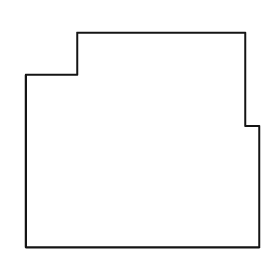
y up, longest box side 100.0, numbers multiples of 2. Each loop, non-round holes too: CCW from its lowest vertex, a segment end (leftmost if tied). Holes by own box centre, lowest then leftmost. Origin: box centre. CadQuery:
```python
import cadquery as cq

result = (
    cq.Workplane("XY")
    .moveTo(-50.0, -46.0)
    .lineTo(50.0, -46.0)
    .lineTo(50.0, 6.0)
    .lineTo(44.0, 6.0)
    .lineTo(44.0, 46.0)
    .lineTo(-28.0, 46.0)
    .lineTo(-28.0, 28.0)
    .lineTo(-50.0, 28.0)
    .close()
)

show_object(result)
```